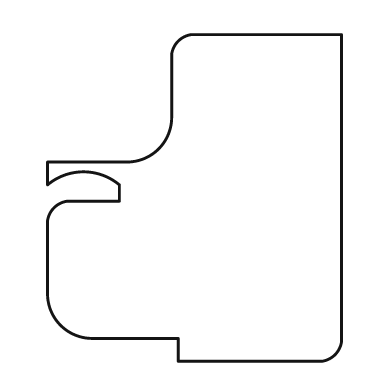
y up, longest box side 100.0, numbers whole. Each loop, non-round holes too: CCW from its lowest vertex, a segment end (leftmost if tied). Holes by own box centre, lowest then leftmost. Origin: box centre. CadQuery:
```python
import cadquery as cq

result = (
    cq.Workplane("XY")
    .moveTo(-5.0, -50.0)
    .lineTo(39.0, -50.0)
    .threePointArc((43.0, -48.0), (45.0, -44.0))
    .lineTo(45.0, 50.0)
    .lineTo(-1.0, 50.0)
    .threePointArc((-5.0, 48.0), (-7.0, 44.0))
    .lineTo(-7.0, 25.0)
    .threePointArc((-11.0, 15.0), (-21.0, 11.0))
    .lineTo(-45.0, 11.0)
    .lineTo(-45.0, 4.0)
    .threePointArc((-34.0, 8.0), (-23.0, 4.0))
    .lineTo(-23.0, -1.0)
    .lineTo(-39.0, -1.0)
    .threePointArc((-43.0, -3.0), (-45.0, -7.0))
    .lineTo(-45.0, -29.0)
    .threePointArc((-41.0, -39.0), (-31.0, -43.0))
    .lineTo(-5.0, -43.0)
    .close()
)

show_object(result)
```